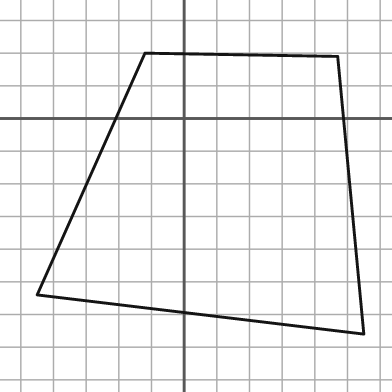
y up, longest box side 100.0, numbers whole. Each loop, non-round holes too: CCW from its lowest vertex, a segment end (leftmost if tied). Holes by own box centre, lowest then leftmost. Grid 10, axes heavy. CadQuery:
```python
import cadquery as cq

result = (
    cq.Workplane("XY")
    .moveTo(55.0, -66.0)
    .lineTo(47.0, 19.0)
    .lineTo(-12.0, 20.0)
    .lineTo(-45.0, -54.0)
    .close()
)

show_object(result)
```